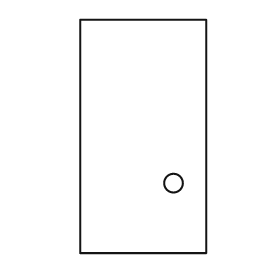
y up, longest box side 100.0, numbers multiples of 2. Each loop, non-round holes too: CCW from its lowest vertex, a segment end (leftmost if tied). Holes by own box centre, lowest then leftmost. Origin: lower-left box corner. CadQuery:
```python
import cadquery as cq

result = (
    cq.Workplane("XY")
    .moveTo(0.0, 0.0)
    .lineTo(54.0, 0.0)
    .lineTo(54.0, 100.0)
    .lineTo(0.0, 100.0)
    .close()
    .moveTo(40.0, 30.0)
    .circle(4.0)
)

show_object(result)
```